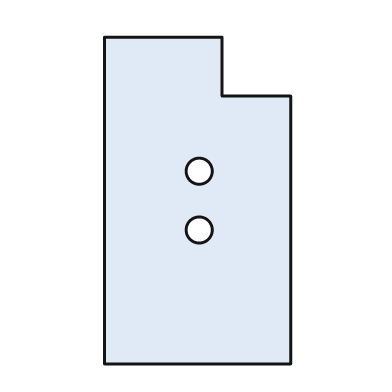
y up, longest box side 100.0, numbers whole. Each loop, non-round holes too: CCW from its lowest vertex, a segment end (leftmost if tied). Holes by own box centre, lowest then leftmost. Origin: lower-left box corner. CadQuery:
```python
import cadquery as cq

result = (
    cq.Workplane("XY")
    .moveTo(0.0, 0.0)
    .lineTo(57.0, 0.0)
    .lineTo(57.0, 82.0)
    .lineTo(36.0, 82.0)
    .lineTo(36.0, 100.0)
    .lineTo(0.0, 100.0)
    .close()
    .moveTo(29.0, 41.0)
    .circle(4.0)
    .moveTo(29.0, 59.0)
    .circle(4.0)
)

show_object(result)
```